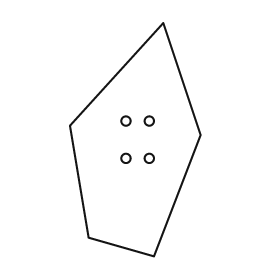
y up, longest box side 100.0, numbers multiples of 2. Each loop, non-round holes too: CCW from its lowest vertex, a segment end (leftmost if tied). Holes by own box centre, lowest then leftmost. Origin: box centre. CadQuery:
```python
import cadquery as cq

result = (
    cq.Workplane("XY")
    .moveTo(8.0, -50.0)
    .lineTo(28.0, 2.0)
    .lineTo(12.0, 50.0)
    .lineTo(-28.0, 6.0)
    .lineTo(-20.0, -42.0)
    .close()
    .moveTo(-4.0, -8.0)
    .circle(2.0)
    .moveTo(6.0, -8.0)
    .circle(2.0)
    .moveTo(-4.0, 8.0)
    .circle(2.0)
    .moveTo(6.0, 8.0)
    .circle(2.0)
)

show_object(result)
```